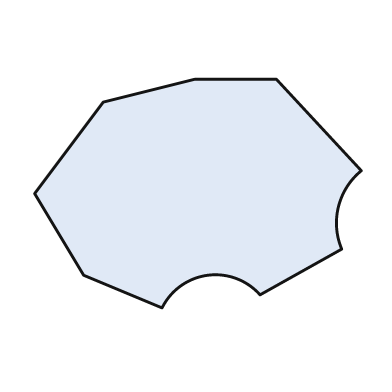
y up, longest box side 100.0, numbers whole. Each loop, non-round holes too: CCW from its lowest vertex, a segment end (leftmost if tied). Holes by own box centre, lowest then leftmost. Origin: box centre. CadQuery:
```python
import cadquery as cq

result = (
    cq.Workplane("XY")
    .moveTo(-11.0, -35.0)
    .threePointArc((3.0, -25.0), (19.0, -31.0))
    .lineTo(44.0, -17.0)
    .threePointArc((43.0, -4.0), (50.0, 7.0))
    .lineTo(24.0, 35.0)
    .lineTo(-1.0, 35.0)
    .lineTo(-29.0, 28.0)
    .lineTo(-50.0, 0.0)
    .lineTo(-35.0, -25.0)
    .close()
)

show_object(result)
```